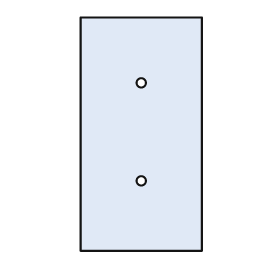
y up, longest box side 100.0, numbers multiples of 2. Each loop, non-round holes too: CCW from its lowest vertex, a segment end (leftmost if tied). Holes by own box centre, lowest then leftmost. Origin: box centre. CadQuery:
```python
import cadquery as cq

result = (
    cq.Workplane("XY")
    .moveTo(-26.0, -50.0)
    .lineTo(26.0, -50.0)
    .lineTo(26.0, 50.0)
    .lineTo(-26.0, 50.0)
    .close()
    .moveTo(0.0, -20.0)
    .circle(2.0)
    .moveTo(0.0, 22.0)
    .circle(2.0)
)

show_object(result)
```